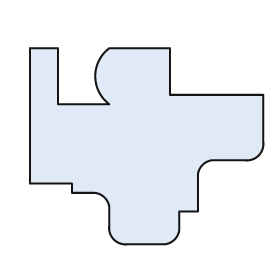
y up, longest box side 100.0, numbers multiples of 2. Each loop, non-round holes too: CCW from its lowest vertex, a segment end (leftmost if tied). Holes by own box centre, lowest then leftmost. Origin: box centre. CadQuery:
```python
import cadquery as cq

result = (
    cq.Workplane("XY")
    .moveTo(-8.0, -42.0)
    .lineTo(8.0, -42.0)
    .threePointArc((12.0, -40.0), (14.0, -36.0))
    .lineTo(14.0, -28.0)
    .lineTo(22.0, -28.0)
    .lineTo(22.0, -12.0)
    .threePointArc((24.0, -8.0), (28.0, -6.0))
    .lineTo(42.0, -6.0)
    .threePointArc((48.0, -4.0), (50.0, 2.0))
    .lineTo(50.0, 22.0)
    .lineTo(10.0, 22.0)
    .lineTo(10.0, 42.0)
    .lineTo(-16.0, 42.0)
    .threePointArc((-22.0, 30.0), (-16.0, 18.0))
    .lineTo(-38.0, 18.0)
    .lineTo(-38.0, 42.0)
    .lineTo(-50.0, 42.0)
    .lineTo(-50.0, -16.0)
    .lineTo(-32.0, -16.0)
    .lineTo(-32.0, -20.0)
    .lineTo(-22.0, -20.0)
    .threePointArc((-18.0, -22.0), (-16.0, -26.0))
    .lineTo(-16.0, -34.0)
    .threePointArc((-14.0, -40.0), (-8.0, -42.0))
    .close()
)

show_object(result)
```